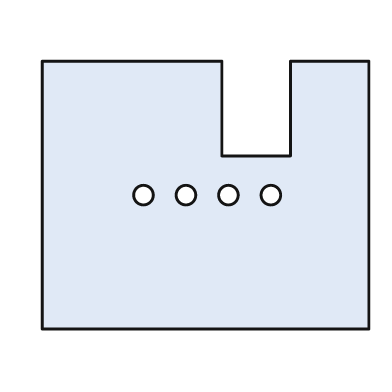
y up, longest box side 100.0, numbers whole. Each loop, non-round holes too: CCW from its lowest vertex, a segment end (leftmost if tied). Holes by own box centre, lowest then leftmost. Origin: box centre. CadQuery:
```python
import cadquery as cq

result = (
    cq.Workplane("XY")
    .moveTo(-50.0, -41.0)
    .lineTo(50.0, -41.0)
    .lineTo(50.0, 41.0)
    .lineTo(26.0, 41.0)
    .lineTo(26.0, 12.0)
    .lineTo(5.0, 12.0)
    .lineTo(5.0, 41.0)
    .lineTo(-50.0, 41.0)
    .close()
    .moveTo(-19.0, 0.0)
    .circle(3.0)
    .moveTo(-6.0, 0.0)
    .circle(3.0)
    .moveTo(7.0, 0.0)
    .circle(3.0)
    .moveTo(20.0, 0.0)
    .circle(3.0)
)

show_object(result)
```